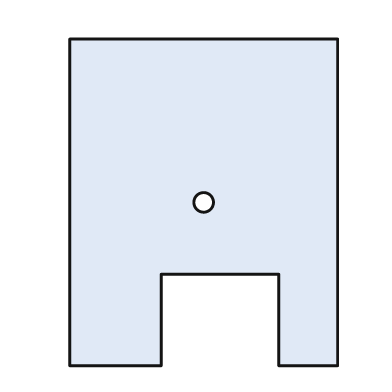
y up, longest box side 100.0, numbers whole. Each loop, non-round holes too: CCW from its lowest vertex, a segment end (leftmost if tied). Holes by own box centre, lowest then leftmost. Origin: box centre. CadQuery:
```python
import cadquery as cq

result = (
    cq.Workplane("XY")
    .moveTo(-41.0, -50.0)
    .lineTo(-13.0, -50.0)
    .lineTo(-13.0, -22.0)
    .lineTo(23.0, -22.0)
    .lineTo(23.0, -50.0)
    .lineTo(41.0, -50.0)
    .lineTo(41.0, 50.0)
    .lineTo(-41.0, 50.0)
    .close()
    .moveTo(0.0, 0.0)
    .circle(3.0)
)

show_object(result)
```